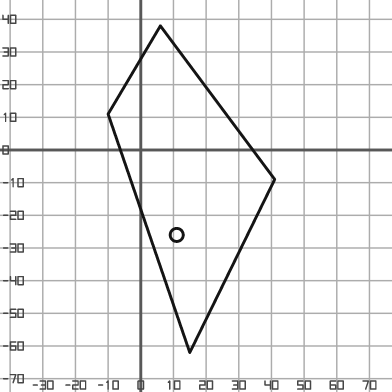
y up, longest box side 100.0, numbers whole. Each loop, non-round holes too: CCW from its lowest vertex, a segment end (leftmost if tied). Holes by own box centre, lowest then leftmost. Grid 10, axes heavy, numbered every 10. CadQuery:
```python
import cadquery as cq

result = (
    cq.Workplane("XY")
    .moveTo(15.0, -62.0)
    .lineTo(41.0, -9.0)
    .lineTo(6.0, 38.0)
    .lineTo(-10.0, 11.0)
    .close()
    .moveTo(11.0, -26.0)
    .circle(2.0)
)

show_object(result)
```